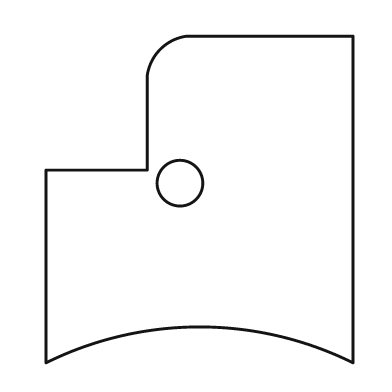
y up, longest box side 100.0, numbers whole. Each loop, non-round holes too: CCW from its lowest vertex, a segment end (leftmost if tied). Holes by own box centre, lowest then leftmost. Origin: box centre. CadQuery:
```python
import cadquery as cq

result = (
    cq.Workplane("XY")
    .moveTo(-47.0, -50.0)
    .threePointArc((0.0, -39.0), (47.0, -50.0))
    .lineTo(47.0, 50.0)
    .lineTo(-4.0, 50.0)
    .threePointArc((-12.0, 46.0), (-16.0, 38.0))
    .lineTo(-16.0, 9.0)
    .lineTo(-47.0, 9.0)
    .close()
    .moveTo(-6.0, 5.0)
    .circle(7.0)
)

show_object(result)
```